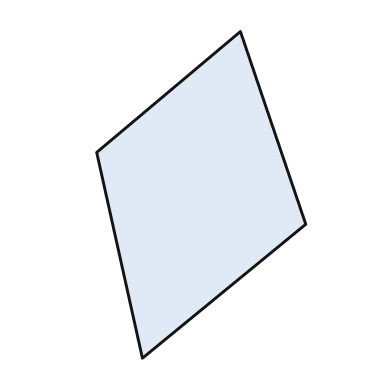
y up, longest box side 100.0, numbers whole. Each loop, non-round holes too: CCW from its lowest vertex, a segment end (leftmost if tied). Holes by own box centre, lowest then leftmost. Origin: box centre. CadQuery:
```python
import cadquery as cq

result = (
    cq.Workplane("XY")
    .moveTo(-18.0, -50.0)
    .lineTo(32.0, -9.0)
    .lineTo(12.0, 50.0)
    .lineTo(-32.0, 13.0)
    .close()
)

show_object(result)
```